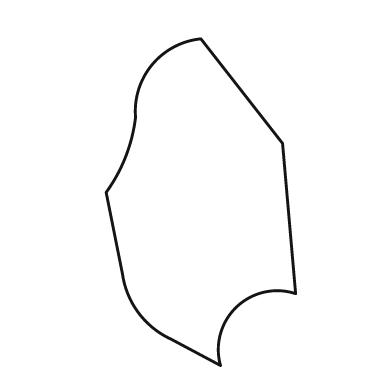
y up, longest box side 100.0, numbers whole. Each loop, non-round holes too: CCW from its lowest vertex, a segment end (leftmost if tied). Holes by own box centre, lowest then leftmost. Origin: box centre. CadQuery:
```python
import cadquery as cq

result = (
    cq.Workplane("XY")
    .moveTo(6.0, -50.0)
    .threePointArc((11.0, -32.0), (29.0, -28.0))
    .lineTo(25.0, 18.0)
    .lineTo(0.0, 50.0)
    .threePointArc((-15.0, 42.0), (-20.0, 26.0))
    .threePointArc((-23.0, 14.0), (-29.0, 3.0))
    .lineTo(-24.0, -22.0)
    .threePointArc((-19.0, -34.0), (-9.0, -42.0))
    .close()
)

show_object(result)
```